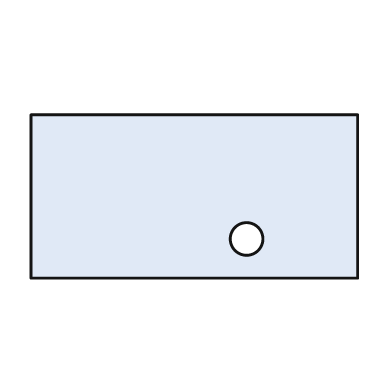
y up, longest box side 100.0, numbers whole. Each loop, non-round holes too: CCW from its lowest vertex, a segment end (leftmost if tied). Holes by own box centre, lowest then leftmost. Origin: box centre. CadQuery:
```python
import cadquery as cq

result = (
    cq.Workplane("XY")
    .moveTo(-50.0, -25.0)
    .lineTo(50.0, -25.0)
    .lineTo(50.0, 25.0)
    .lineTo(-50.0, 25.0)
    .close()
    .moveTo(16.0, -13.0)
    .circle(5.0)
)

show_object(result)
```